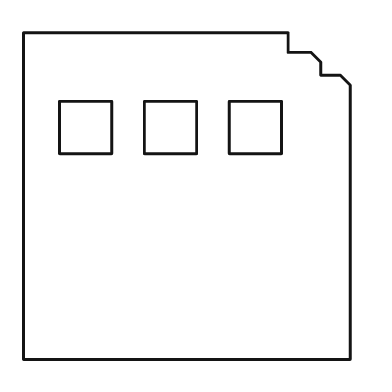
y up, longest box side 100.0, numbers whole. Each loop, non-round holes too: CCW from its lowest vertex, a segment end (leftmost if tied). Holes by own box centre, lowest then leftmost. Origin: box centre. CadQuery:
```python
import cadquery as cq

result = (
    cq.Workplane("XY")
    .moveTo(-50.0, -50.0)
    .lineTo(50.0, -50.0)
    .lineTo(50.0, 34.0)
    .lineTo(47.0, 37.0)
    .lineTo(41.0, 37.0)
    .lineTo(41.0, 41.0)
    .lineTo(38.0, 44.0)
    .lineTo(31.0, 44.0)
    .lineTo(31.0, 50.0)
    .lineTo(-50.0, 50.0)
    .close()
    .moveTo(-39.0, 13.0)
    .lineTo(-23.0, 13.0)
    .lineTo(-23.0, 29.0)
    .lineTo(-39.0, 29.0)
    .close()
    .moveTo(-13.0, 13.0)
    .lineTo(3.0, 13.0)
    .lineTo(3.0, 29.0)
    .lineTo(-13.0, 29.0)
    .close()
    .moveTo(13.0, 13.0)
    .lineTo(29.0, 13.0)
    .lineTo(29.0, 29.0)
    .lineTo(13.0, 29.0)
    .close()
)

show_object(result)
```